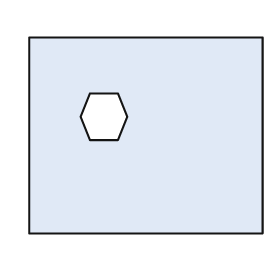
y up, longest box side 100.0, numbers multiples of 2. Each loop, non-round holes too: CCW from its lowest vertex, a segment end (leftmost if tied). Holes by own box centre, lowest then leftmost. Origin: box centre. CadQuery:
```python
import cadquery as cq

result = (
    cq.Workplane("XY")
    .moveTo(-50.0, -42.0)
    .lineTo(50.0, -42.0)
    .lineTo(50.0, 42.0)
    .lineTo(-50.0, 42.0)
    .close()
    .moveTo(-24.0, -2.0)
    .lineTo(-12.0, -2.0)
    .lineTo(-8.0, 8.0)
    .lineTo(-12.0, 18.0)
    .lineTo(-24.0, 18.0)
    .lineTo(-28.0, 8.0)
    .close()
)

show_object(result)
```